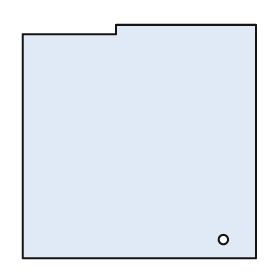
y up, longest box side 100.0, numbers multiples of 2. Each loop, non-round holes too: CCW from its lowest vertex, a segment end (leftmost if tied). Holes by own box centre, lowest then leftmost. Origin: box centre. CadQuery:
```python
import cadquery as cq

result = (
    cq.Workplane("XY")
    .moveTo(-50.0, -50.0)
    .lineTo(50.0, -50.0)
    .lineTo(50.0, 50.0)
    .lineTo(-10.0, 50.0)
    .lineTo(-10.0, 46.0)
    .lineTo(-50.0, 46.0)
    .close()
    .moveTo(36.0, -42.0)
    .circle(2.0)
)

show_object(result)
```